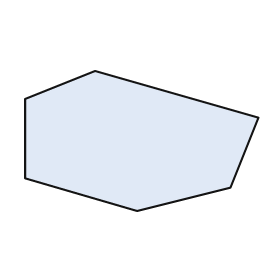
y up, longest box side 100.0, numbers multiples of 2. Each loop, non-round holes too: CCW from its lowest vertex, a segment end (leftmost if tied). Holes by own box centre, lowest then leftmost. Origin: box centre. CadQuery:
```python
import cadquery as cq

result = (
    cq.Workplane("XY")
    .moveTo(-2.0, -30.0)
    .lineTo(38.0, -20.0)
    .lineTo(50.0, 10.0)
    .lineTo(-20.0, 30.0)
    .lineTo(-50.0, 18.0)
    .lineTo(-50.0, -16.0)
    .close()
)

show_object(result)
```